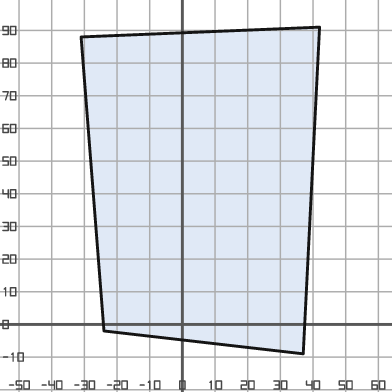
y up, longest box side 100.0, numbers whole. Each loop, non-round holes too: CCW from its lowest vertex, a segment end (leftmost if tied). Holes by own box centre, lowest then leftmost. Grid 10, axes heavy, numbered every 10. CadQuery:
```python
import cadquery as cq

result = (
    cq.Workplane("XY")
    .moveTo(37.0, -9.0)
    .lineTo(42.0, 91.0)
    .lineTo(-31.0, 88.0)
    .lineTo(-24.0, -2.0)
    .close()
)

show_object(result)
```